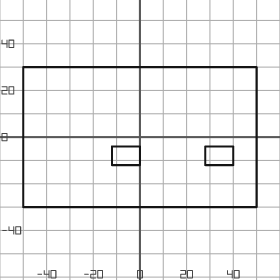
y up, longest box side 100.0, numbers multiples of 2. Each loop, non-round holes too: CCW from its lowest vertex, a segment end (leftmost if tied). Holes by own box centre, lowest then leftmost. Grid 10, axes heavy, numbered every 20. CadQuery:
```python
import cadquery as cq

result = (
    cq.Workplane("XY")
    .moveTo(-50.0, -30.0)
    .lineTo(50.0, -30.0)
    .lineTo(50.0, 30.0)
    .lineTo(-50.0, 30.0)
    .close()
    .moveTo(-12.0, -12.0)
    .lineTo(0.0, -12.0)
    .lineTo(0.0, -4.0)
    .lineTo(-12.0, -4.0)
    .close()
    .moveTo(28.0, -12.0)
    .lineTo(40.0, -12.0)
    .lineTo(40.0, -4.0)
    .lineTo(28.0, -4.0)
    .close()
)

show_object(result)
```